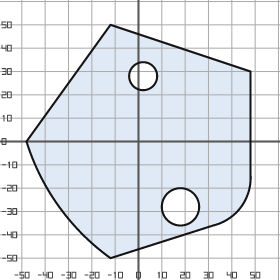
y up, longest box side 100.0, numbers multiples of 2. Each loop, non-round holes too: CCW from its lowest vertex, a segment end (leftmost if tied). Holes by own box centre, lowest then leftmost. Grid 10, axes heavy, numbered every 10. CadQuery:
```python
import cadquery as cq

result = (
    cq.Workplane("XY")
    .moveTo(-12.0, -50.0)
    .lineTo(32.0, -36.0)
    .threePointArc((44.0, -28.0), (48.0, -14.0))
    .lineTo(48.0, 30.0)
    .lineTo(-12.0, 50.0)
    .lineTo(-48.0, 0.0)
    .threePointArc((-34.0, -28.0), (-12.0, -50.0))
    .close()
    .moveTo(18.0, -28.0)
    .circle(8.0)
    .moveTo(2.0, 28.0)
    .circle(6.0)
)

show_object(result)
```